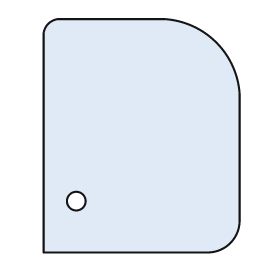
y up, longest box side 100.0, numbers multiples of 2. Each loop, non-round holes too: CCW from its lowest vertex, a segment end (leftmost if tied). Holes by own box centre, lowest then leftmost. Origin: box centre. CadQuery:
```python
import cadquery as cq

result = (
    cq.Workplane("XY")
    .moveTo(-42.0, -50.0)
    .lineTo(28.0, -50.0)
    .threePointArc((38.0, -46.0), (42.0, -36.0))
    .lineTo(42.0, 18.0)
    .threePointArc((32.0, 40.0), (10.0, 50.0))
    .lineTo(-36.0, 50.0)
    .threePointArc((-40.0, 48.0), (-42.0, 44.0))
    .close()
    .moveTo(-28.0, -28.0)
    .circle(4.0)
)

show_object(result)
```